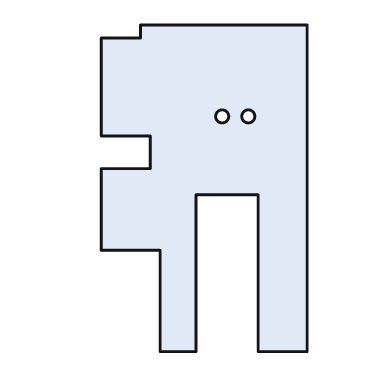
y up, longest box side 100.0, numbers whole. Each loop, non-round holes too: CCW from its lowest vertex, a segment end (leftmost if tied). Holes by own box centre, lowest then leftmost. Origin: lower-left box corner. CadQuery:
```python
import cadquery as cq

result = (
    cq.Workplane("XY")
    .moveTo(18.0, 0.0)
    .lineTo(29.0, 0.0)
    .lineTo(29.0, 48.0)
    .lineTo(48.0, 48.0)
    .lineTo(48.0, 0.0)
    .lineTo(63.0, 0.0)
    .lineTo(63.0, 100.0)
    .lineTo(12.0, 100.0)
    .lineTo(12.0, 96.0)
    .lineTo(0.0, 96.0)
    .lineTo(0.0, 66.0)
    .lineTo(15.0, 66.0)
    .lineTo(15.0, 56.0)
    .lineTo(0.0, 56.0)
    .lineTo(0.0, 31.0)
    .lineTo(18.0, 31.0)
    .close()
    .moveTo(37.0, 72.0)
    .circle(2.0)
    .moveTo(45.0, 72.0)
    .circle(2.0)
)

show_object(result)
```